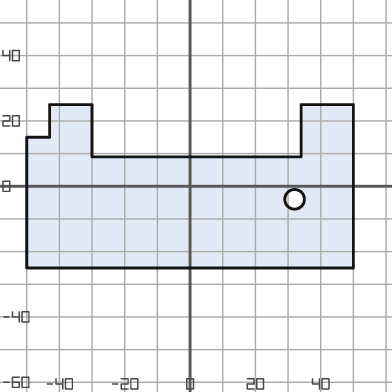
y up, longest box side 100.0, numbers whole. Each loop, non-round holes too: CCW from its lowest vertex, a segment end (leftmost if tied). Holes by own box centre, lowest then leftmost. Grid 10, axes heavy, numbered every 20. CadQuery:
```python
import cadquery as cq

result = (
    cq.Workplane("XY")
    .moveTo(-50.0, -25.0)
    .lineTo(50.0, -25.0)
    .lineTo(50.0, 25.0)
    .lineTo(34.0, 25.0)
    .lineTo(34.0, 9.0)
    .lineTo(-30.0, 9.0)
    .lineTo(-30.0, 25.0)
    .lineTo(-43.0, 25.0)
    .lineTo(-43.0, 15.0)
    .lineTo(-50.0, 15.0)
    .close()
    .moveTo(32.0, -4.0)
    .circle(3.0)
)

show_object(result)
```